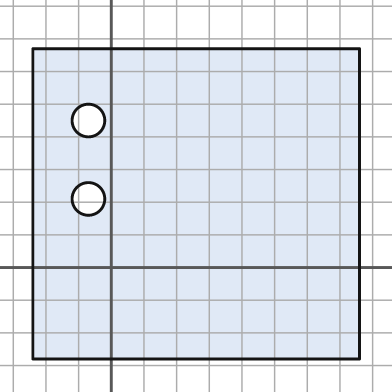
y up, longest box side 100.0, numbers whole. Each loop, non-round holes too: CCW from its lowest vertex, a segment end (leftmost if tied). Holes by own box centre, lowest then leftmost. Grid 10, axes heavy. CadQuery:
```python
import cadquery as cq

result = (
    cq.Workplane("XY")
    .moveTo(-24.0, -28.0)
    .lineTo(76.0, -28.0)
    .lineTo(76.0, 67.0)
    .lineTo(-24.0, 67.0)
    .close()
    .moveTo(-7.0, 21.0)
    .circle(5.0)
    .moveTo(-7.0, 45.0)
    .circle(5.0)
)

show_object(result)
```